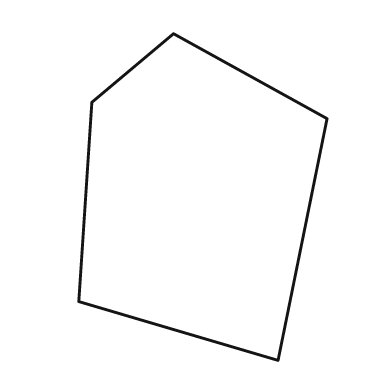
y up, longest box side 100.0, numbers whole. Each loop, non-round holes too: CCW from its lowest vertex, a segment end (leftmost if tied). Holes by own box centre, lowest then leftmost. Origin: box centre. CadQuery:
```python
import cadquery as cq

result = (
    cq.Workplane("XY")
    .moveTo(23.0, -50.0)
    .lineTo(38.0, 24.0)
    .lineTo(-9.0, 50.0)
    .lineTo(-34.0, 29.0)
    .lineTo(-38.0, -32.0)
    .close()
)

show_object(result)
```